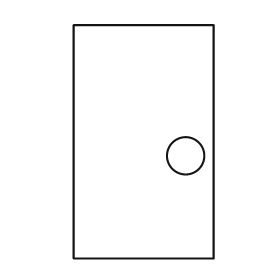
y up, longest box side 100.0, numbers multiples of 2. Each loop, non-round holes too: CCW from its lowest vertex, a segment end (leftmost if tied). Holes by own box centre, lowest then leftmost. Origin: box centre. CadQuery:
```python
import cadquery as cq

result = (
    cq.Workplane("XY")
    .moveTo(-30.0, -50.0)
    .lineTo(30.0, -50.0)
    .lineTo(30.0, 50.0)
    .lineTo(-30.0, 50.0)
    .close()
    .moveTo(18.0, -6.0)
    .circle(8.0)
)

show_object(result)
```